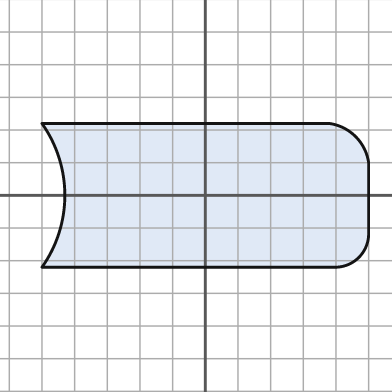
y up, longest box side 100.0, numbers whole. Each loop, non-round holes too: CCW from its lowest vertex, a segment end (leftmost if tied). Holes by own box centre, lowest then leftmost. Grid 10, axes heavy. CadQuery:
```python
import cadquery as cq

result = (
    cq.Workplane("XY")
    .moveTo(-50.0, -22.0)
    .lineTo(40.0, -22.0)
    .threePointArc((47.0, -19.0), (50.0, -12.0))
    .lineTo(50.0, 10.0)
    .threePointArc((46.0, 18.0), (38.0, 22.0))
    .lineTo(-50.0, 22.0)
    .threePointArc((-43.0, 0.0), (-50.0, -22.0))
    .close()
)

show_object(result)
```